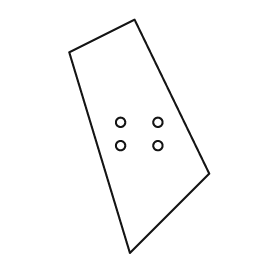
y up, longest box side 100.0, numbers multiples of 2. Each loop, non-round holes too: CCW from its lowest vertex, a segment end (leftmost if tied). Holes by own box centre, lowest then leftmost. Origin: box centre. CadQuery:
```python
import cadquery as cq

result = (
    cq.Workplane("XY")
    .moveTo(-4.0, -50.0)
    .lineTo(30.0, -16.0)
    .lineTo(-2.0, 50.0)
    .lineTo(-30.0, 36.0)
    .close()
    .moveTo(-8.0, -4.0)
    .circle(2.0)
    .moveTo(8.0, -4.0)
    .circle(2.0)
    .moveTo(-8.0, 6.0)
    .circle(2.0)
    .moveTo(8.0, 6.0)
    .circle(2.0)
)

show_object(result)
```